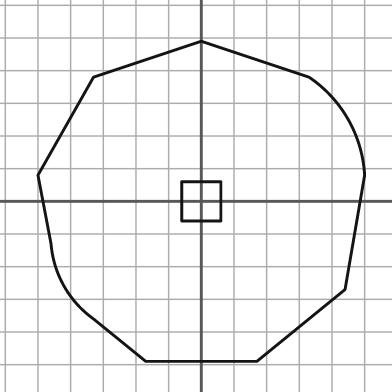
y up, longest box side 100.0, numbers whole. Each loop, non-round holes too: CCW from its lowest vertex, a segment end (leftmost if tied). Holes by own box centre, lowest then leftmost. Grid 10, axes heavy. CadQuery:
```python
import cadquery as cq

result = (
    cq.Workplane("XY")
    .moveTo(-17.0, -49.0)
    .lineTo(17.0, -49.0)
    .lineTo(44.0, -27.0)
    .lineTo(50.0, 8.0)
    .threePointArc((45.0, 25.0), (33.0, 38.0))
    .lineTo(0.0, 49.0)
    .lineTo(-33.0, 38.0)
    .lineTo(-50.0, 8.0)
    .lineTo(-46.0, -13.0)
    .threePointArc((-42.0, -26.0), (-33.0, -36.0))
    .close()
    .moveTo(-6.0, -6.0)
    .lineTo(6.0, -6.0)
    .lineTo(6.0, 6.0)
    .lineTo(-6.0, 6.0)
    .close()
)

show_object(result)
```